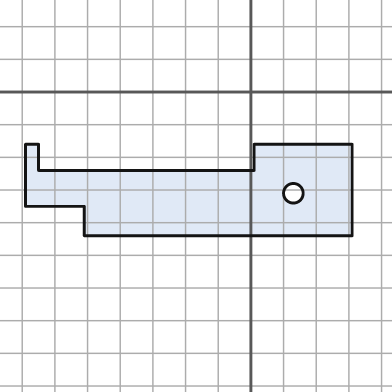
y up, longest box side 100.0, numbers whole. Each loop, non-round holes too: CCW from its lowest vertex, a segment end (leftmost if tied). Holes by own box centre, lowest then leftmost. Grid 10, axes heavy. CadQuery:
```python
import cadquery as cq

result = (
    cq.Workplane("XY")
    .moveTo(-51.0, -44.0)
    .lineTo(31.0, -44.0)
    .lineTo(31.0, -16.0)
    .lineTo(1.0, -16.0)
    .lineTo(1.0, -24.0)
    .lineTo(-65.0, -24.0)
    .lineTo(-65.0, -16.0)
    .lineTo(-69.0, -16.0)
    .lineTo(-69.0, -35.0)
    .lineTo(-51.0, -35.0)
    .close()
    .moveTo(13.0, -31.0)
    .circle(3.0)
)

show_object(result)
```